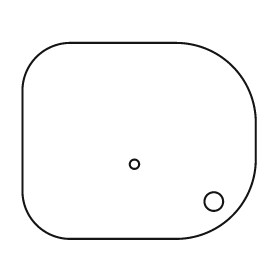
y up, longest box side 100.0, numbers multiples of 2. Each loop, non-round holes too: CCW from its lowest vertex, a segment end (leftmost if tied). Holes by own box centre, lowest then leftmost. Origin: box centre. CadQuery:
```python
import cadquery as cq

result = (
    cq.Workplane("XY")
    .moveTo(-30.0, -42.0)
    .lineTo(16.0, -42.0)
    .threePointArc((40.0, -32.0), (50.0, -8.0))
    .lineTo(50.0, 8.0)
    .threePointArc((40.0, 32.0), (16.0, 42.0))
    .lineTo(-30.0, 42.0)
    .threePointArc((-44.0, 36.0), (-50.0, 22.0))
    .lineTo(-50.0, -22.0)
    .threePointArc((-44.0, -36.0), (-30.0, -42.0))
    .close()
    .moveTo(32.0, -26.0)
    .circle(4.0)
    .moveTo(-2.0, -10.0)
    .circle(2.0)
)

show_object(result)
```